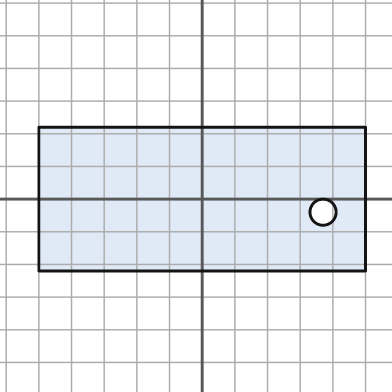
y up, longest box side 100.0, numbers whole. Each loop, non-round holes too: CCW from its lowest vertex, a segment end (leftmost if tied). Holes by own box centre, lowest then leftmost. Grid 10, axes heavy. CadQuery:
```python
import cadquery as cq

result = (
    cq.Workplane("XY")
    .moveTo(-50.0, -22.0)
    .lineTo(50.0, -22.0)
    .lineTo(50.0, 22.0)
    .lineTo(-50.0, 22.0)
    .close()
    .moveTo(37.0, -4.0)
    .circle(4.0)
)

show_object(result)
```